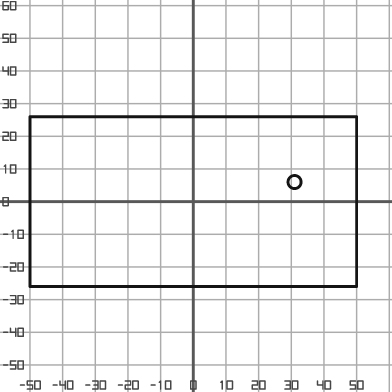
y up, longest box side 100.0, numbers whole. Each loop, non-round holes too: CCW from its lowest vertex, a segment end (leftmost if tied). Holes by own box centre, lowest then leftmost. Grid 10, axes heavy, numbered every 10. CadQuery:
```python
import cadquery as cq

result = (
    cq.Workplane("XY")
    .moveTo(-50.0, -26.0)
    .lineTo(50.0, -26.0)
    .lineTo(50.0, 26.0)
    .lineTo(-50.0, 26.0)
    .close()
    .moveTo(31.0, 6.0)
    .circle(2.0)
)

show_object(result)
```